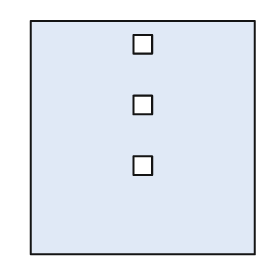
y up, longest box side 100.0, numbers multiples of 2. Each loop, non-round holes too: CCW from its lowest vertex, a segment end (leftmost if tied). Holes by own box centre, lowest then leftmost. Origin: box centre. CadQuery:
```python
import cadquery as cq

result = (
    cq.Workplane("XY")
    .moveTo(-48.0, -50.0)
    .lineTo(48.0, -50.0)
    .lineTo(48.0, 50.0)
    .lineTo(-48.0, 50.0)
    .close()
    .moveTo(-4.0, -16.0)
    .lineTo(4.0, -16.0)
    .lineTo(4.0, -8.0)
    .lineTo(-4.0, -8.0)
    .close()
    .moveTo(-4.0, 10.0)
    .lineTo(4.0, 10.0)
    .lineTo(4.0, 18.0)
    .lineTo(-4.0, 18.0)
    .close()
    .moveTo(-4.0, 36.0)
    .lineTo(4.0, 36.0)
    .lineTo(4.0, 44.0)
    .lineTo(-4.0, 44.0)
    .close()
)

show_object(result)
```